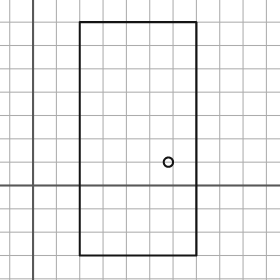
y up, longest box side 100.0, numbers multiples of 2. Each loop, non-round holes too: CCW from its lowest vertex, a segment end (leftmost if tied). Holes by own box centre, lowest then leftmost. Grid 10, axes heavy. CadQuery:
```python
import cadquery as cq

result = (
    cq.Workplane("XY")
    .moveTo(20.0, -30.0)
    .lineTo(70.0, -30.0)
    .lineTo(70.0, 70.0)
    .lineTo(20.0, 70.0)
    .close()
    .moveTo(58.0, 10.0)
    .circle(2.0)
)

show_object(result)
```